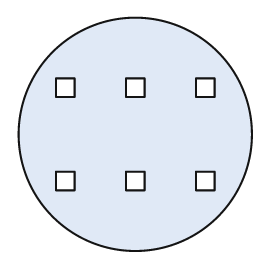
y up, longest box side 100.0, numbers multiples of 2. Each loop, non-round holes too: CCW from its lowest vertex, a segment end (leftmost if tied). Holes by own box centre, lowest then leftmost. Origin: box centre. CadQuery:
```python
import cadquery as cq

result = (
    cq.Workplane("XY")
    .moveTo(0.0, 0.0)
    .circle(50.0)
    .moveTo(-34.0, -24.0)
    .lineTo(-26.0, -24.0)
    .lineTo(-26.0, -16.0)
    .lineTo(-34.0, -16.0)
    .close()
    .moveTo(-4.0, -24.0)
    .lineTo(4.0, -24.0)
    .lineTo(4.0, -16.0)
    .lineTo(-4.0, -16.0)
    .close()
    .moveTo(26.0, -24.0)
    .lineTo(34.0, -24.0)
    .lineTo(34.0, -16.0)
    .lineTo(26.0, -16.0)
    .close()
    .moveTo(-34.0, 16.0)
    .lineTo(-26.0, 16.0)
    .lineTo(-26.0, 24.0)
    .lineTo(-34.0, 24.0)
    .close()
    .moveTo(-4.0, 16.0)
    .lineTo(4.0, 16.0)
    .lineTo(4.0, 24.0)
    .lineTo(-4.0, 24.0)
    .close()
    .moveTo(26.0, 16.0)
    .lineTo(34.0, 16.0)
    .lineTo(34.0, 24.0)
    .lineTo(26.0, 24.0)
    .close()
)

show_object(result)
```